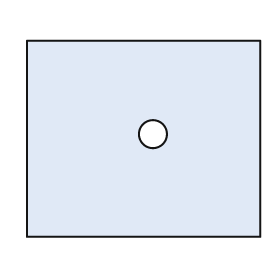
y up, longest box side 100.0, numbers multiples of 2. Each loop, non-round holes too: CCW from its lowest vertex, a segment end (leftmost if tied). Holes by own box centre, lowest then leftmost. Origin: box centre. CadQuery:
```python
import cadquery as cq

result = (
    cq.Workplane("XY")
    .moveTo(-50.0, -42.0)
    .lineTo(50.0, -42.0)
    .lineTo(50.0, 42.0)
    .lineTo(-50.0, 42.0)
    .close()
    .moveTo(4.0, 2.0)
    .circle(6.0)
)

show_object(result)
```